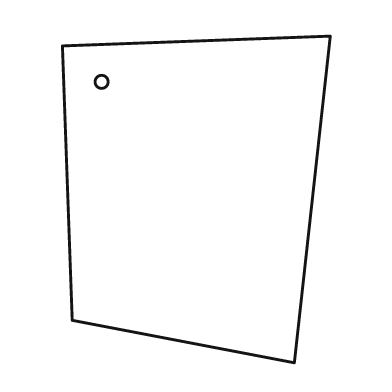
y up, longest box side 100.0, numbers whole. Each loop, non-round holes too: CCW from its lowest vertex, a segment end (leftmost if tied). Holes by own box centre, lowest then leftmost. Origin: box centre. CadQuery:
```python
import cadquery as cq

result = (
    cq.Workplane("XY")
    .moveTo(30.0, -50.0)
    .lineTo(41.0, 50.0)
    .lineTo(-41.0, 47.0)
    .lineTo(-38.0, -37.0)
    .close()
    .moveTo(-29.0, 36.0)
    .circle(2.0)
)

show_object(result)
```